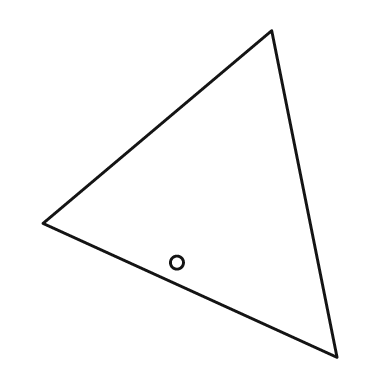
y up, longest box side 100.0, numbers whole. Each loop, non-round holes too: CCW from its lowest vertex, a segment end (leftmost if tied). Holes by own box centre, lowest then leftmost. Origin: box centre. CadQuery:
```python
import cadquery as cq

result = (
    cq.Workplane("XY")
    .moveTo(45.0, -50.0)
    .lineTo(25.0, 50.0)
    .lineTo(-45.0, -9.0)
    .close()
    .moveTo(-4.0, -21.0)
    .circle(2.0)
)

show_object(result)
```